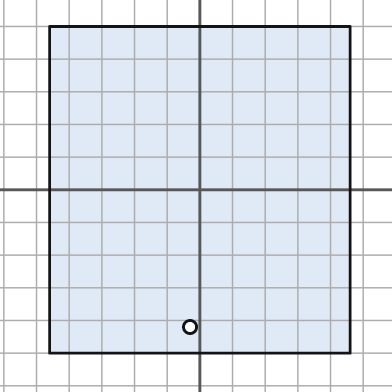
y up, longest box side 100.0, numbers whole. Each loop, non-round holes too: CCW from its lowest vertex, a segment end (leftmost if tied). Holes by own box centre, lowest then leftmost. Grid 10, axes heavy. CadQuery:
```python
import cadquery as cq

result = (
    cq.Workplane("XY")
    .moveTo(-46.0, -50.0)
    .lineTo(46.0, -50.0)
    .lineTo(46.0, 50.0)
    .lineTo(-46.0, 50.0)
    .close()
    .moveTo(-3.0, -42.0)
    .circle(2.0)
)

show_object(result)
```